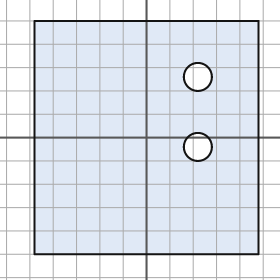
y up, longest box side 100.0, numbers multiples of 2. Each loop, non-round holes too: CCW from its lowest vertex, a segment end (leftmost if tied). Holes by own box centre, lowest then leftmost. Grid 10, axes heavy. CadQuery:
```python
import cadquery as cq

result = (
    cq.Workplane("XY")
    .moveTo(-48.0, -50.0)
    .lineTo(48.0, -50.0)
    .lineTo(48.0, 50.0)
    .lineTo(-48.0, 50.0)
    .close()
    .moveTo(22.0, -4.0)
    .circle(6.0)
    .moveTo(22.0, 26.0)
    .circle(6.0)
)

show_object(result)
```